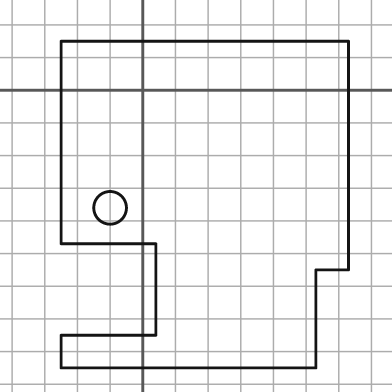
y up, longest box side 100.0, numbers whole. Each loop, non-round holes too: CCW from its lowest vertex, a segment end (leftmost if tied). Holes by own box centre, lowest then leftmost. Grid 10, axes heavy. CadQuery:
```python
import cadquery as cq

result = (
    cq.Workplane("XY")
    .moveTo(-25.0, -85.0)
    .lineTo(53.0, -85.0)
    .lineTo(53.0, -55.0)
    .lineTo(63.0, -55.0)
    .lineTo(63.0, 15.0)
    .lineTo(-25.0, 15.0)
    .lineTo(-25.0, -47.0)
    .lineTo(4.0, -47.0)
    .lineTo(4.0, -75.0)
    .lineTo(-25.0, -75.0)
    .close()
    .moveTo(-10.0, -36.0)
    .circle(5.0)
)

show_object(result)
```